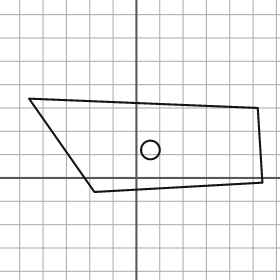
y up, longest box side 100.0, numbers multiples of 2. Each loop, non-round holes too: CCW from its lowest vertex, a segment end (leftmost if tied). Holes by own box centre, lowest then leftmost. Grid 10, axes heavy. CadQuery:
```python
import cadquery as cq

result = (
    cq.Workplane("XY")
    .moveTo(-18.0, -6.0)
    .lineTo(54.0, -2.0)
    .lineTo(52.0, 30.0)
    .lineTo(-46.0, 34.0)
    .close()
    .moveTo(6.0, 12.0)
    .circle(4.0)
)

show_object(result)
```